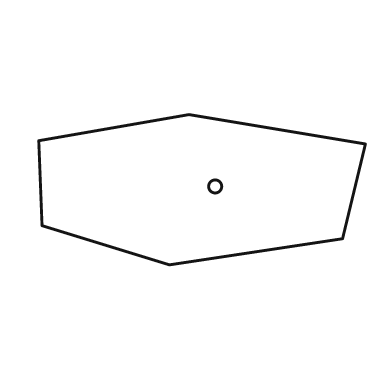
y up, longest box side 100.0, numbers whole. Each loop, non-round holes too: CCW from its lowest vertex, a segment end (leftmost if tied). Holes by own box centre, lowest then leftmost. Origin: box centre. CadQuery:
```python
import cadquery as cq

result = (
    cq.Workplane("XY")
    .moveTo(-10.0, -23.0)
    .lineTo(43.0, -15.0)
    .lineTo(50.0, 14.0)
    .lineTo(-4.0, 23.0)
    .lineTo(-50.0, 15.0)
    .lineTo(-49.0, -11.0)
    .close()
    .moveTo(4.0, 1.0)
    .circle(2.0)
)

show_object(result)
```